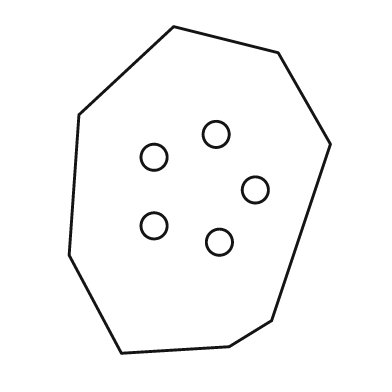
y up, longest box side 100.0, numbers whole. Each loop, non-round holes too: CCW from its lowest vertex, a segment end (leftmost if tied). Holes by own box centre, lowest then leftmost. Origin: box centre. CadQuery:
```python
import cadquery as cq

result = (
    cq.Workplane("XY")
    .moveTo(-24.0, -50.0)
    .lineTo(9.0, -48.0)
    .lineTo(22.0, -40.0)
    .lineTo(40.0, 14.0)
    .lineTo(24.0, 42.0)
    .lineTo(-8.0, 50.0)
    .lineTo(-37.0, 23.0)
    .lineTo(-40.0, -20.0)
    .close()
    .moveTo(6.0, -16.0)
    .circle(4.0)
    .moveTo(-14.0, -11.0)
    .circle(4.0)
    .moveTo(17.0, 0.0)
    .circle(4.0)
    .moveTo(-14.0, 10.0)
    .circle(4.0)
    .moveTo(5.0, 17.0)
    .circle(4.0)
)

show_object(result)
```